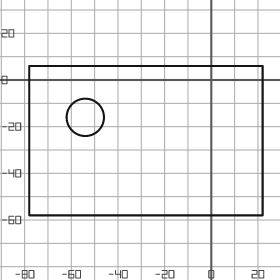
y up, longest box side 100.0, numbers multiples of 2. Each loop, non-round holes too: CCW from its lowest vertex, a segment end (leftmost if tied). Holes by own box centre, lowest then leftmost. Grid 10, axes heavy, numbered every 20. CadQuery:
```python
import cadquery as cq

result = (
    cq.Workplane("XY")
    .moveTo(-78.0, -58.0)
    .lineTo(22.0, -58.0)
    .lineTo(22.0, 6.0)
    .lineTo(-78.0, 6.0)
    .close()
    .moveTo(-54.0, -16.0)
    .circle(8.0)
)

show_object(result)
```